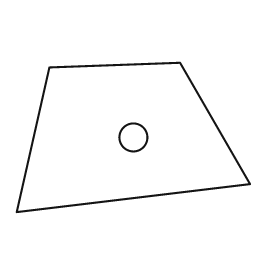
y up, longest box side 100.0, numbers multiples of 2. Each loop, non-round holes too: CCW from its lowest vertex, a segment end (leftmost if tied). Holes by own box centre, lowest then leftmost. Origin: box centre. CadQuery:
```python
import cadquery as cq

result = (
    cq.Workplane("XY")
    .moveTo(-50.0, -32.0)
    .lineTo(50.0, -20.0)
    .lineTo(20.0, 32.0)
    .lineTo(-36.0, 30.0)
    .close()
    .moveTo(0.0, 0.0)
    .circle(6.0)
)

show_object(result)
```